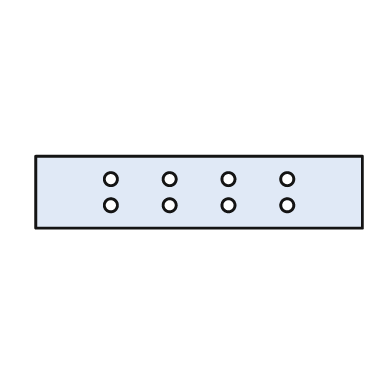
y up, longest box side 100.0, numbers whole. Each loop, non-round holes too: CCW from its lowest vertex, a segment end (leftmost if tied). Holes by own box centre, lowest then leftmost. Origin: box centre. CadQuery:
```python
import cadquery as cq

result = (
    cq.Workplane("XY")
    .moveTo(-50.0, -11.0)
    .lineTo(50.0, -11.0)
    .lineTo(50.0, 11.0)
    .lineTo(-50.0, 11.0)
    .close()
    .moveTo(-27.0, -4.0)
    .circle(2.0)
    .moveTo(-9.0, -4.0)
    .circle(2.0)
    .moveTo(9.0, -4.0)
    .circle(2.0)
    .moveTo(27.0, -4.0)
    .circle(2.0)
    .moveTo(-27.0, 4.0)
    .circle(2.0)
    .moveTo(-9.0, 4.0)
    .circle(2.0)
    .moveTo(9.0, 4.0)
    .circle(2.0)
    .moveTo(27.0, 4.0)
    .circle(2.0)
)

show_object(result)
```